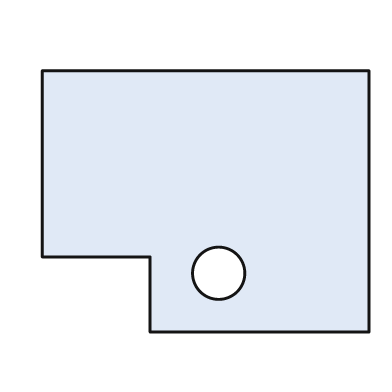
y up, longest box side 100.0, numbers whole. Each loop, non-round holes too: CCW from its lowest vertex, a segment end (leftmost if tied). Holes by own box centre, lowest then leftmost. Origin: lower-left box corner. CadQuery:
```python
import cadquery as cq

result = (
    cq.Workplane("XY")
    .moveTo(33.0, 0.0)
    .lineTo(100.0, 0.0)
    .lineTo(100.0, 80.0)
    .lineTo(0.0, 80.0)
    .lineTo(0.0, 23.0)
    .lineTo(33.0, 23.0)
    .close()
    .moveTo(54.0, 18.0)
    .circle(8.0)
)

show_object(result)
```